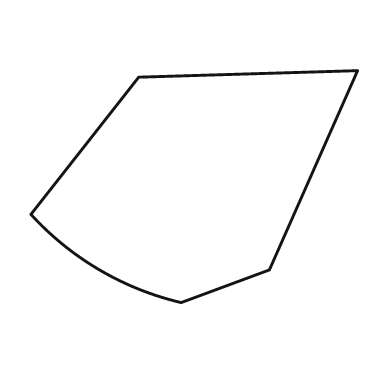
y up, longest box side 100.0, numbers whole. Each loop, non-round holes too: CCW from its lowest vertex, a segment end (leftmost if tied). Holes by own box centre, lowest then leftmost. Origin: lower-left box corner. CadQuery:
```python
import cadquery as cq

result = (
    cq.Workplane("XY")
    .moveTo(46.0, 0.0)
    .lineTo(73.0, 10.0)
    .lineTo(100.0, 71.0)
    .lineTo(33.0, 69.0)
    .lineTo(0.0, 27.0)
    .threePointArc((21.0, 10.0), (46.0, 0.0))
    .close()
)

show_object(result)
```